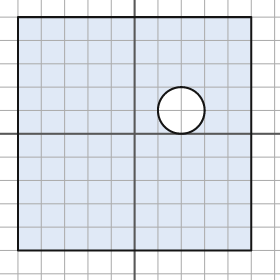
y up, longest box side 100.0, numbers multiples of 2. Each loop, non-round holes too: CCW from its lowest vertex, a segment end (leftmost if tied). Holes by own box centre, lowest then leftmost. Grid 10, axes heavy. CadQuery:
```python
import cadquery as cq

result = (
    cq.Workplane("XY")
    .moveTo(-50.0, -50.0)
    .lineTo(50.0, -50.0)
    .lineTo(50.0, 50.0)
    .lineTo(-50.0, 50.0)
    .close()
    .moveTo(20.0, 10.0)
    .circle(10.0)
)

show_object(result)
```